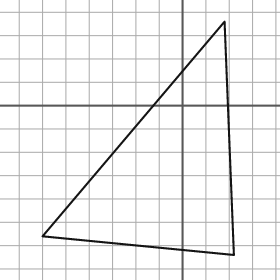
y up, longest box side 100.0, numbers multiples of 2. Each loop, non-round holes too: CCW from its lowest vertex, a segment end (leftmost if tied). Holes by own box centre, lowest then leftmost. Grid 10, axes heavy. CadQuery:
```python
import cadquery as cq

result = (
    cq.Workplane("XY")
    .moveTo(22.0, -64.0)
    .lineTo(18.0, 36.0)
    .lineTo(-60.0, -56.0)
    .close()
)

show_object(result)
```